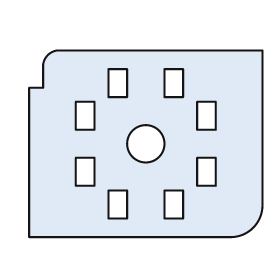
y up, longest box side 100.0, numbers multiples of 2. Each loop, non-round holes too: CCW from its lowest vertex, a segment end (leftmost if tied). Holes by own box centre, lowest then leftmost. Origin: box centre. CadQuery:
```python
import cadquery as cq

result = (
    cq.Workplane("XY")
    .moveTo(-50.0, -40.0)
    .lineTo(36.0, -40.0)
    .threePointArc((46.0, -36.0), (50.0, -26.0))
    .lineTo(50.0, 40.0)
    .lineTo(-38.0, 40.0)
    .threePointArc((-42.0, 38.0), (-44.0, 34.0))
    .lineTo(-44.0, 24.0)
    .lineTo(-50.0, 24.0)
    .close()
    .moveTo(-16.0, -32.0)
    .lineTo(-8.0, -32.0)
    .lineTo(-8.0, -20.0)
    .lineTo(-16.0, -20.0)
    .close()
    .moveTo(8.0, -32.0)
    .lineTo(16.0, -32.0)
    .lineTo(16.0, -20.0)
    .lineTo(8.0, -20.0)
    .close()
    .moveTo(-30.0, -18.0)
    .lineTo(-22.0, -18.0)
    .lineTo(-22.0, -6.0)
    .lineTo(-30.0, -6.0)
    .close()
    .moveTo(22.0, -18.0)
    .lineTo(30.0, -18.0)
    .lineTo(30.0, -6.0)
    .lineTo(22.0, -6.0)
    .close()
    .moveTo(0.0, 0.0)
    .circle(8.0)
    .moveTo(-30.0, 6.0)
    .lineTo(-22.0, 6.0)
    .lineTo(-22.0, 18.0)
    .lineTo(-30.0, 18.0)
    .close()
    .moveTo(22.0, 6.0)
    .lineTo(30.0, 6.0)
    .lineTo(30.0, 18.0)
    .lineTo(22.0, 18.0)
    .close()
    .moveTo(-16.0, 20.0)
    .lineTo(-8.0, 20.0)
    .lineTo(-8.0, 32.0)
    .lineTo(-16.0, 32.0)
    .close()
    .moveTo(8.0, 20.0)
    .lineTo(16.0, 20.0)
    .lineTo(16.0, 32.0)
    .lineTo(8.0, 32.0)
    .close()
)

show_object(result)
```